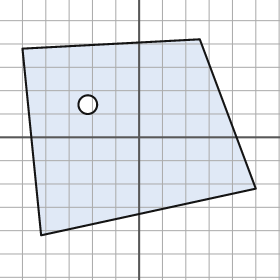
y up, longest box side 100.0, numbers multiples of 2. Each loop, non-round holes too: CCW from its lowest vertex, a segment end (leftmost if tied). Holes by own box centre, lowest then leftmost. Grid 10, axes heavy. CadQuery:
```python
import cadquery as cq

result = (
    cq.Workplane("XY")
    .moveTo(-42.0, -42.0)
    .lineTo(50.0, -22.0)
    .lineTo(26.0, 42.0)
    .lineTo(-50.0, 38.0)
    .close()
    .moveTo(-22.0, 14.0)
    .circle(4.0)
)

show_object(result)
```